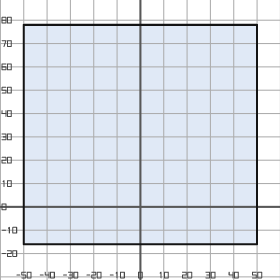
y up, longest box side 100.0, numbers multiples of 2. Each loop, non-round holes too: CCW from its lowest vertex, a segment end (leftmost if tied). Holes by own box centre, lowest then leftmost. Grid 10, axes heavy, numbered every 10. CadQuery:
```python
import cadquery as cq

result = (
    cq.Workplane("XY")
    .moveTo(-50.0, -16.0)
    .lineTo(50.0, -16.0)
    .lineTo(50.0, 78.0)
    .lineTo(-50.0, 78.0)
    .close()
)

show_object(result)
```